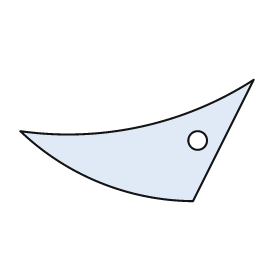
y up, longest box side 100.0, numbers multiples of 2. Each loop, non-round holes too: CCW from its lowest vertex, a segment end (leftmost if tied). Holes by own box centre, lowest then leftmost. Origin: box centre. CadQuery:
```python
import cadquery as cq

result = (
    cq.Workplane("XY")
    .moveTo(24.0, -26.0)
    .lineTo(50.0, 26.0)
    .threePointArc((2.0, 6.0), (-50.0, 4.0))
    .threePointArc((-16.0, -18.0), (24.0, -26.0))
    .close()
    .moveTo(26.0, 0.0)
    .circle(4.0)
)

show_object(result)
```